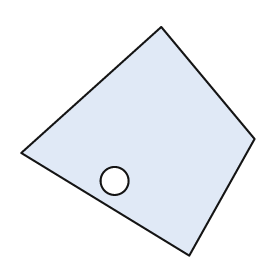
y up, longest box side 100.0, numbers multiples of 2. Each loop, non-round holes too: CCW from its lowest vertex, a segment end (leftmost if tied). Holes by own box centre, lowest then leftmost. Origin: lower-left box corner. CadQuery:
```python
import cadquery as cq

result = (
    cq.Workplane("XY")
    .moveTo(72.0, 0.0)
    .lineTo(100.0, 50.0)
    .lineTo(60.0, 98.0)
    .lineTo(0.0, 44.0)
    .close()
    .moveTo(40.0, 32.0)
    .circle(6.0)
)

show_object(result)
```